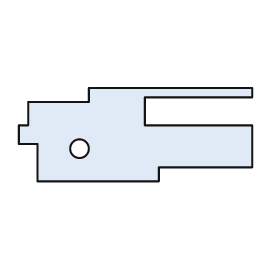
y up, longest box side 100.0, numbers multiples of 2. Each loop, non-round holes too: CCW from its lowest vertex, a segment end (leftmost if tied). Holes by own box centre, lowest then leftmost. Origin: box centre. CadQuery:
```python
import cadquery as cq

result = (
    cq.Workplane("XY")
    .moveTo(-42.0, -20.0)
    .lineTo(10.0, -20.0)
    .lineTo(10.0, -14.0)
    .lineTo(50.0, -14.0)
    .lineTo(50.0, 4.0)
    .lineTo(4.0, 4.0)
    .lineTo(4.0, 16.0)
    .lineTo(50.0, 16.0)
    .lineTo(50.0, 20.0)
    .lineTo(-20.0, 20.0)
    .lineTo(-20.0, 14.0)
    .lineTo(-46.0, 14.0)
    .lineTo(-46.0, 4.0)
    .lineTo(-50.0, 4.0)
    .lineTo(-50.0, -4.0)
    .lineTo(-42.0, -4.0)
    .close()
    .moveTo(-24.0, -6.0)
    .circle(4.0)
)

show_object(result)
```